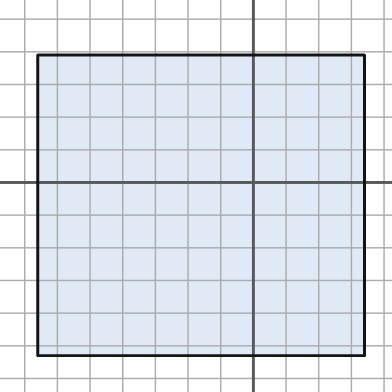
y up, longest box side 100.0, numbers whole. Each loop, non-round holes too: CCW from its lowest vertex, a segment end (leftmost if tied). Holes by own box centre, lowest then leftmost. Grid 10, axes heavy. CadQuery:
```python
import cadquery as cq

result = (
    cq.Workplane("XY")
    .moveTo(-66.0, -53.0)
    .lineTo(34.0, -53.0)
    .lineTo(34.0, 39.0)
    .lineTo(-66.0, 39.0)
    .close()
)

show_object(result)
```